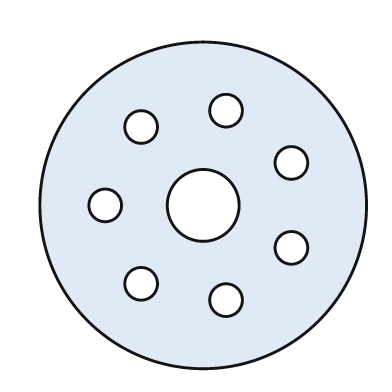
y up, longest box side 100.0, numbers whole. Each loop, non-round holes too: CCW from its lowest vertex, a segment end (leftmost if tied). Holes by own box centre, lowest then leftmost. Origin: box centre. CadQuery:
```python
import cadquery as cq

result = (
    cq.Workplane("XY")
    .moveTo(0.0, 0.0)
    .circle(50.0)
    .moveTo(7.0, -29.0)
    .circle(5.0)
    .moveTo(-19.0, -24.0)
    .circle(5.0)
    .moveTo(27.0, -13.0)
    .circle(5.0)
    .moveTo(-30.0, 0.0)
    .circle(5.0)
    .moveTo(0.0, 0.0)
    .circle(11.0)
    .moveTo(27.0, 13.0)
    .circle(5.0)
    .moveTo(-19.0, 24.0)
    .circle(5.0)
    .moveTo(7.0, 29.0)
    .circle(5.0)
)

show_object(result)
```